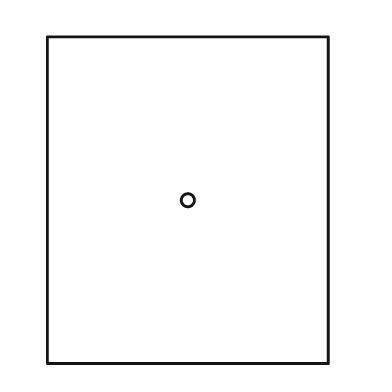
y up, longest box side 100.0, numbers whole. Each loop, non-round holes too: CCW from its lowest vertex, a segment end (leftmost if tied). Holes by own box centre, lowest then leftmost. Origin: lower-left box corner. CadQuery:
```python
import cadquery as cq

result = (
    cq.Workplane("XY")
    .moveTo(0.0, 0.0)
    .lineTo(86.0, 0.0)
    .lineTo(86.0, 100.0)
    .lineTo(0.0, 100.0)
    .close()
    .moveTo(43.0, 50.0)
    .circle(2.0)
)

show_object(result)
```